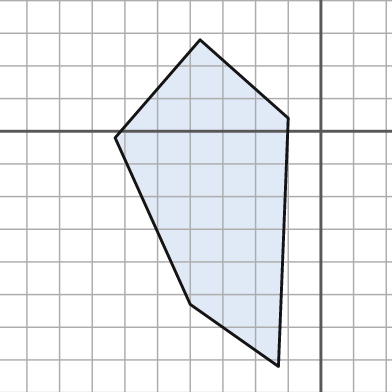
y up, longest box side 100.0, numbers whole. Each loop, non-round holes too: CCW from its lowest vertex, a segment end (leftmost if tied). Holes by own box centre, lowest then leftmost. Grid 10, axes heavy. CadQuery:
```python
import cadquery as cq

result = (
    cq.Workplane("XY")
    .moveTo(-13.0, -72.0)
    .lineTo(-10.0, 4.0)
    .lineTo(-37.0, 28.0)
    .lineTo(-63.0, -2.0)
    .lineTo(-40.0, -53.0)
    .close()
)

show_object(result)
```